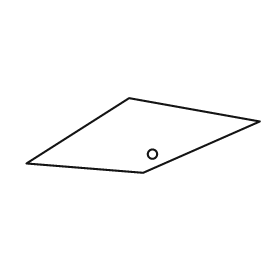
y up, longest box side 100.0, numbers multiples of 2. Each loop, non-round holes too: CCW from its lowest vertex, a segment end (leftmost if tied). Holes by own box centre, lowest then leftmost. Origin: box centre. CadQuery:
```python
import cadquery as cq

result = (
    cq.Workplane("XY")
    .moveTo(0.0, -16.0)
    .lineTo(50.0, 6.0)
    .lineTo(-6.0, 16.0)
    .lineTo(-50.0, -12.0)
    .close()
    .moveTo(4.0, -8.0)
    .circle(2.0)
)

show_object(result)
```